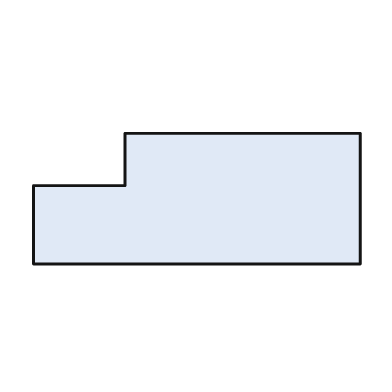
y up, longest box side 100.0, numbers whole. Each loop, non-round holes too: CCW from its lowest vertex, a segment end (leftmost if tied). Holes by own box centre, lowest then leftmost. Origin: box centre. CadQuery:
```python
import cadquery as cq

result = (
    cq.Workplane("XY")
    .moveTo(-50.0, -20.0)
    .lineTo(50.0, -20.0)
    .lineTo(50.0, 20.0)
    .lineTo(-22.0, 20.0)
    .lineTo(-22.0, 4.0)
    .lineTo(-50.0, 4.0)
    .close()
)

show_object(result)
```